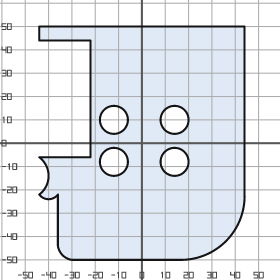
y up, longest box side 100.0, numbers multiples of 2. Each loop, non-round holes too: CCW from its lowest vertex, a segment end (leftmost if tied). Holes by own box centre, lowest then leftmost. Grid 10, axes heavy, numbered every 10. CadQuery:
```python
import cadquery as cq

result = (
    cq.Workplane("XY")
    .moveTo(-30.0, -50.0)
    .lineTo(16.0, -50.0)
    .threePointArc((36.0, -42.0), (44.0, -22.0))
    .lineTo(44.0, 50.0)
    .lineTo(-44.0, 50.0)
    .lineTo(-44.0, 44.0)
    .lineTo(-22.0, 44.0)
    .lineTo(-22.0, -6.0)
    .lineTo(-44.0, -6.0)
    .threePointArc((-40.0, -14.0), (-44.0, -22.0))
    .threePointArc((-40.0, -24.0), (-36.0, -22.0))
    .lineTo(-36.0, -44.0)
    .threePointArc((-34.0, -48.0), (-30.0, -50.0))
    .close()
    .moveTo(-12.0, -8.0)
    .circle(6.0)
    .moveTo(14.0, -8.0)
    .circle(6.0)
    .moveTo(-12.0, 10.0)
    .circle(6.0)
    .moveTo(14.0, 10.0)
    .circle(6.0)
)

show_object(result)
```